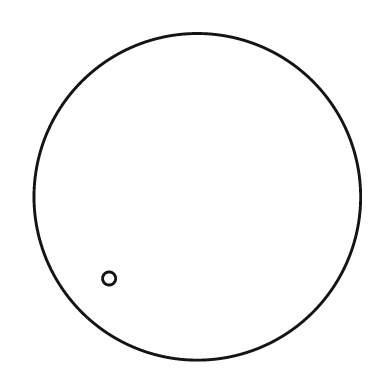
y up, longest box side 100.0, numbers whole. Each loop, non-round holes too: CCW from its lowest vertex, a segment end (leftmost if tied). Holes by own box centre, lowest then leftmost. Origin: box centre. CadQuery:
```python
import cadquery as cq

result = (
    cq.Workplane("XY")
    .moveTo(0.0, 0.0)
    .circle(50.0)
    .moveTo(-27.0, -25.0)
    .circle(2.0)
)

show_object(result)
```